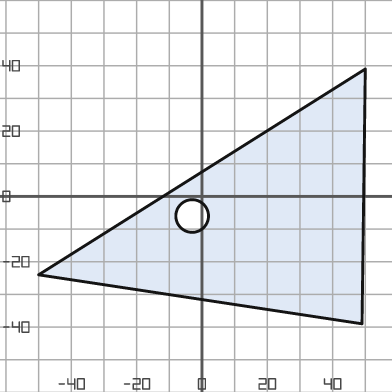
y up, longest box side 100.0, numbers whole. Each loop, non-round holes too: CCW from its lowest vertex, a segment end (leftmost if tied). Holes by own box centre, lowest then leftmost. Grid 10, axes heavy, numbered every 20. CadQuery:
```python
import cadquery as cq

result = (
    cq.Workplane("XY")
    .moveTo(49.0, -39.0)
    .lineTo(50.0, 39.0)
    .lineTo(-50.0, -24.0)
    .close()
    .moveTo(-3.0, -6.0)
    .circle(5.0)
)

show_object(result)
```